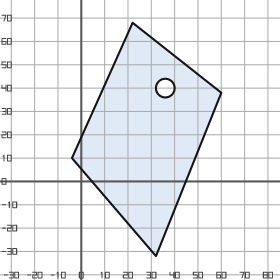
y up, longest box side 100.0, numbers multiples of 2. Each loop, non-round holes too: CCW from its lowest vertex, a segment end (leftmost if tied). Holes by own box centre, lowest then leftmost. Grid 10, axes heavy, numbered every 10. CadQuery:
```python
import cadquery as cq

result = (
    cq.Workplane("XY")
    .moveTo(32.0, -32.0)
    .lineTo(60.0, 38.0)
    .lineTo(22.0, 68.0)
    .lineTo(-4.0, 10.0)
    .close()
    .moveTo(36.0, 40.0)
    .circle(4.0)
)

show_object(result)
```